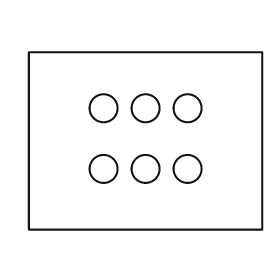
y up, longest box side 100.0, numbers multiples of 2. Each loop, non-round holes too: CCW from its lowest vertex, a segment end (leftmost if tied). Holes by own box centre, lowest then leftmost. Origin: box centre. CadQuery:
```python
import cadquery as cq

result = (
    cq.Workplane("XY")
    .moveTo(-50.0, -38.0)
    .lineTo(50.0, -38.0)
    .lineTo(50.0, 38.0)
    .lineTo(-50.0, 38.0)
    .close()
    .moveTo(-18.0, -12.0)
    .circle(6.0)
    .moveTo(0.0, -12.0)
    .circle(6.0)
    .moveTo(18.0, -12.0)
    .circle(6.0)
    .moveTo(-18.0, 14.0)
    .circle(6.0)
    .moveTo(0.0, 14.0)
    .circle(6.0)
    .moveTo(18.0, 14.0)
    .circle(6.0)
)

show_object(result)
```